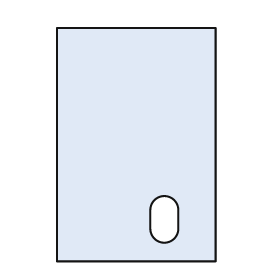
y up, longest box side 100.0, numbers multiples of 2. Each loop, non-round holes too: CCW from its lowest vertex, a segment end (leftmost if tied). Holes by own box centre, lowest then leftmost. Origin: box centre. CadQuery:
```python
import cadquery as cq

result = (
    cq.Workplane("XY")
    .moveTo(-34.0, -50.0)
    .lineTo(34.0, -50.0)
    .lineTo(34.0, 50.0)
    .lineTo(-34.0, 50.0)
    .close()
    .moveTo(6.0, -36.0)
    .threePointArc((12.0, -42.0), (18.0, -36.0))
    .lineTo(18.0, -28.0)
    .threePointArc((12.0, -22.0), (6.0, -28.0))
    .close()
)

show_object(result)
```